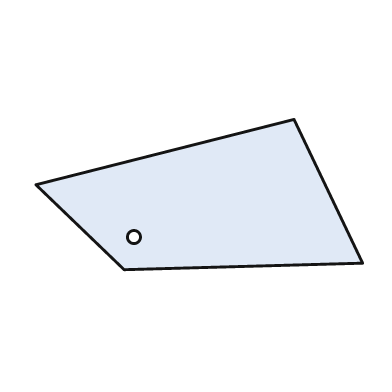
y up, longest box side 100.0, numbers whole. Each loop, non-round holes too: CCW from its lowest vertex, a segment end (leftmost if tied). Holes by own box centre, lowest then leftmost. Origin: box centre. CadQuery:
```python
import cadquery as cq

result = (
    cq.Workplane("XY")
    .moveTo(-23.0, -23.0)
    .lineTo(50.0, -21.0)
    .lineTo(29.0, 23.0)
    .lineTo(-50.0, 3.0)
    .close()
    .moveTo(-20.0, -13.0)
    .circle(2.0)
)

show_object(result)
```